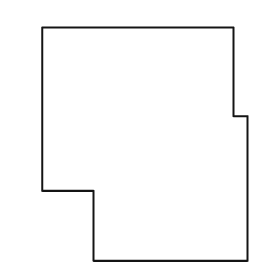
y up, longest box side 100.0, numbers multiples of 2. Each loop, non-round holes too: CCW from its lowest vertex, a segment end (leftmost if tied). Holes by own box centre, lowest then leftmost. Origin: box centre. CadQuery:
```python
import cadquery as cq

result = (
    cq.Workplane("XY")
    .moveTo(-22.0, -50.0)
    .lineTo(44.0, -50.0)
    .lineTo(44.0, 12.0)
    .lineTo(38.0, 12.0)
    .lineTo(38.0, 50.0)
    .lineTo(-44.0, 50.0)
    .lineTo(-44.0, -20.0)
    .lineTo(-22.0, -20.0)
    .close()
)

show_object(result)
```